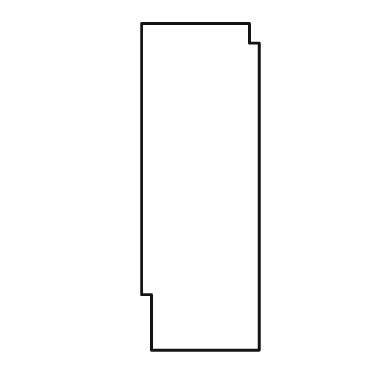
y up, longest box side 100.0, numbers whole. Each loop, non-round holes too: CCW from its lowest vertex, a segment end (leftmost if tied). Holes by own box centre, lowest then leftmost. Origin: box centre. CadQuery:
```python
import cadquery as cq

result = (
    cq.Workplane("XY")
    .moveTo(-15.0, -50.0)
    .lineTo(18.0, -50.0)
    .lineTo(18.0, 44.0)
    .lineTo(15.0, 44.0)
    .lineTo(15.0, 50.0)
    .lineTo(-18.0, 50.0)
    .lineTo(-18.0, -33.0)
    .lineTo(-15.0, -33.0)
    .close()
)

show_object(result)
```